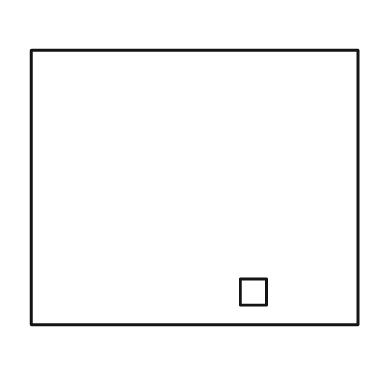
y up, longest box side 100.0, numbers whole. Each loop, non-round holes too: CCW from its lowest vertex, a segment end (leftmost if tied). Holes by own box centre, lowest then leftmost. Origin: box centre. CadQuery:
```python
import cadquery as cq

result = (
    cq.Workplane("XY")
    .moveTo(-50.0, -42.0)
    .lineTo(50.0, -42.0)
    .lineTo(50.0, 42.0)
    .lineTo(-50.0, 42.0)
    .close()
    .moveTo(14.0, -36.0)
    .lineTo(22.0, -36.0)
    .lineTo(22.0, -28.0)
    .lineTo(14.0, -28.0)
    .close()
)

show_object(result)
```